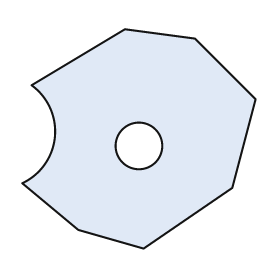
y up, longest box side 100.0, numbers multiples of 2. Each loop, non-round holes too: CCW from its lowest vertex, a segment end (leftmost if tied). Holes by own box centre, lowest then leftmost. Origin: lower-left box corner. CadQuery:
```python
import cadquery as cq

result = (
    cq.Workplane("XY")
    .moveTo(52.0, 0.0)
    .lineTo(90.0, 26.0)
    .lineTo(100.0, 64.0)
    .lineTo(74.0, 90.0)
    .lineTo(44.0, 94.0)
    .lineTo(4.0, 70.0)
    .threePointArc((14.0, 48.0), (0.0, 28.0))
    .lineTo(24.0, 8.0)
    .close()
    .moveTo(50.0, 44.0)
    .circle(10.0)
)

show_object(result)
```